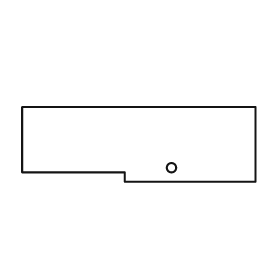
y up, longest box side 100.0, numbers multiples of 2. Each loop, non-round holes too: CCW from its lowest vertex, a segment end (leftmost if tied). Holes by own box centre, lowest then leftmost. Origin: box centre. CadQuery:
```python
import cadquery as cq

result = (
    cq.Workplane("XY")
    .moveTo(-6.0, -16.0)
    .lineTo(50.0, -16.0)
    .lineTo(50.0, 16.0)
    .lineTo(-50.0, 16.0)
    .lineTo(-50.0, -12.0)
    .lineTo(-6.0, -12.0)
    .close()
    .moveTo(14.0, -10.0)
    .circle(2.0)
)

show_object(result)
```